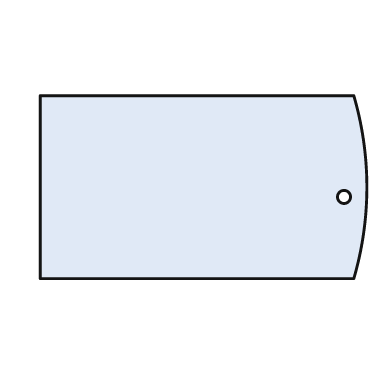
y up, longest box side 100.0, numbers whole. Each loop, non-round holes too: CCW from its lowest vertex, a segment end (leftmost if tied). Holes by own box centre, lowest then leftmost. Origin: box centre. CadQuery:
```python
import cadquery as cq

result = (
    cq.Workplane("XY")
    .moveTo(-50.0, -28.0)
    .lineTo(46.0, -28.0)
    .threePointArc((50.0, 0.0), (46.0, 28.0))
    .lineTo(-50.0, 28.0)
    .close()
    .moveTo(43.0, -3.0)
    .circle(2.0)
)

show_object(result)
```